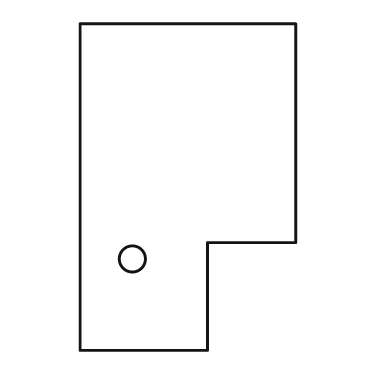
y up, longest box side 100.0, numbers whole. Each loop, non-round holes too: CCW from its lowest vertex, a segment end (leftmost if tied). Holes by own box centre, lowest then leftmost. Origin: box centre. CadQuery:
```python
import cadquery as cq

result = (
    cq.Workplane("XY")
    .moveTo(-33.0, -50.0)
    .lineTo(6.0, -50.0)
    .lineTo(6.0, -17.0)
    .lineTo(33.0, -17.0)
    .lineTo(33.0, 50.0)
    .lineTo(-33.0, 50.0)
    .close()
    .moveTo(-17.0, -22.0)
    .circle(4.0)
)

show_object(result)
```